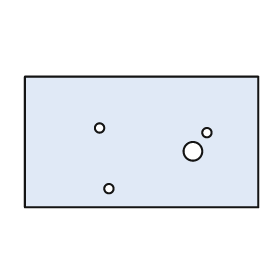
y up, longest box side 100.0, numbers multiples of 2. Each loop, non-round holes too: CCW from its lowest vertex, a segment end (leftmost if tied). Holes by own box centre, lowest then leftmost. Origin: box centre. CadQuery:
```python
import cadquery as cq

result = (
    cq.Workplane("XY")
    .moveTo(-50.0, -28.0)
    .lineTo(50.0, -28.0)
    .lineTo(50.0, 28.0)
    .lineTo(-50.0, 28.0)
    .close()
    .moveTo(-14.0, -20.0)
    .circle(2.0)
    .moveTo(22.0, -4.0)
    .circle(4.0)
    .moveTo(28.0, 4.0)
    .circle(2.0)
    .moveTo(-18.0, 6.0)
    .circle(2.0)
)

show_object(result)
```